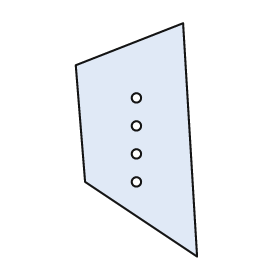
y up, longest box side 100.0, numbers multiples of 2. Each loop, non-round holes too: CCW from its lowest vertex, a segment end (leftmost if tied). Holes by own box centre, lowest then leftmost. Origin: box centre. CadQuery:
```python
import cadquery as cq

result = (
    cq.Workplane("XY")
    .moveTo(26.0, -50.0)
    .lineTo(20.0, 50.0)
    .lineTo(-26.0, 32.0)
    .lineTo(-22.0, -18.0)
    .close()
    .moveTo(0.0, -18.0)
    .circle(2.0)
    .moveTo(0.0, -6.0)
    .circle(2.0)
    .moveTo(0.0, 6.0)
    .circle(2.0)
    .moveTo(0.0, 18.0)
    .circle(2.0)
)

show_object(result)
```